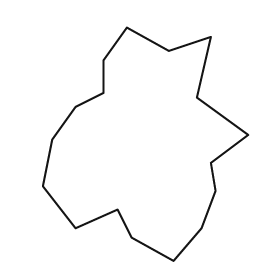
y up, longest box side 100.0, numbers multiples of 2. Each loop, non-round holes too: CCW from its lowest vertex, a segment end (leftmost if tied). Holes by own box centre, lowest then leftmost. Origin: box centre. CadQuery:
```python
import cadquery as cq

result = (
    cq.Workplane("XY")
    .moveTo(12.0, -50.0)
    .lineTo(24.0, -36.0)
    .lineTo(30.0, -20.0)
    .lineTo(28.0, -8.0)
    .lineTo(44.0, 4.0)
    .lineTo(22.0, 20.0)
    .lineTo(28.0, 46.0)
    .lineTo(10.0, 40.0)
    .lineTo(-8.0, 50.0)
    .lineTo(-18.0, 36.0)
    .lineTo(-18.0, 22.0)
    .lineTo(-30.0, 16.0)
    .lineTo(-40.0, 2.0)
    .lineTo(-44.0, -18.0)
    .lineTo(-30.0, -36.0)
    .lineTo(-12.0, -28.0)
    .lineTo(-6.0, -40.0)
    .close()
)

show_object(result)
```